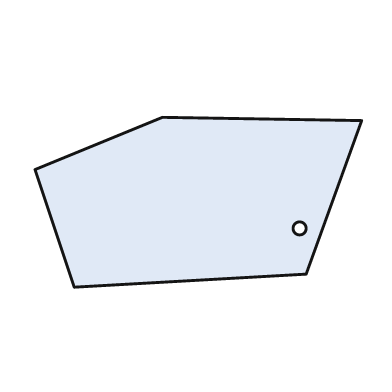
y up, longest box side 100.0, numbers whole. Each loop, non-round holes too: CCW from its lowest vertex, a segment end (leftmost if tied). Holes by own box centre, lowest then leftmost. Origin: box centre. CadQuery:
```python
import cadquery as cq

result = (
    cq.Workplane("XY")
    .moveTo(-38.0, -26.0)
    .lineTo(33.0, -22.0)
    .lineTo(50.0, 25.0)
    .lineTo(-11.0, 26.0)
    .lineTo(-50.0, 10.0)
    .close()
    .moveTo(31.0, -8.0)
    .circle(2.0)
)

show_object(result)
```